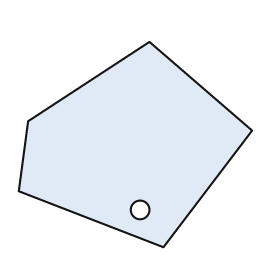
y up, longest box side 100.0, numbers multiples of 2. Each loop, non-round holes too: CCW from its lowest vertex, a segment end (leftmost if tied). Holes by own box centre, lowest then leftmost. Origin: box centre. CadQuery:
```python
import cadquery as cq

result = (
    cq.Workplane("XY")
    .moveTo(12.0, -44.0)
    .lineTo(50.0, 6.0)
    .lineTo(6.0, 44.0)
    .lineTo(-46.0, 10.0)
    .lineTo(-50.0, -20.0)
    .close()
    .moveTo(2.0, -28.0)
    .circle(4.0)
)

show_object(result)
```